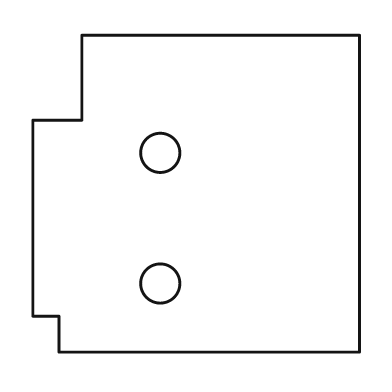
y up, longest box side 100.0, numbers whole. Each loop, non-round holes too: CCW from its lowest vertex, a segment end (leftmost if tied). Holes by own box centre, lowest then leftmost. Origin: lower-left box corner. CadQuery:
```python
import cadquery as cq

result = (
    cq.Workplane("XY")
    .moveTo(8.0, 0.0)
    .lineTo(100.0, 0.0)
    .lineTo(100.0, 97.0)
    .lineTo(15.0, 97.0)
    .lineTo(15.0, 71.0)
    .lineTo(0.0, 71.0)
    .lineTo(0.0, 11.0)
    .lineTo(8.0, 11.0)
    .close()
    .moveTo(39.0, 21.0)
    .circle(6.0)
    .moveTo(39.0, 61.0)
    .circle(6.0)
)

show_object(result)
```